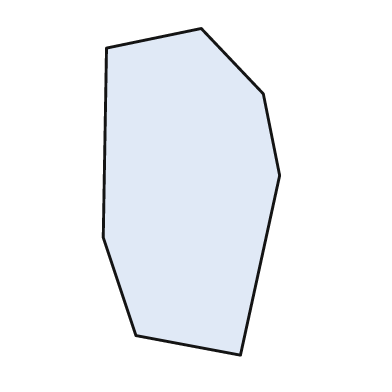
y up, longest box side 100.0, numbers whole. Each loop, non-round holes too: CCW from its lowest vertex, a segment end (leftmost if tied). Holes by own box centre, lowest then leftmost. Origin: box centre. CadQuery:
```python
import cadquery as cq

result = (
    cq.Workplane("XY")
    .moveTo(15.0, -50.0)
    .lineTo(27.0, 5.0)
    .lineTo(22.0, 30.0)
    .lineTo(3.0, 50.0)
    .lineTo(-26.0, 44.0)
    .lineTo(-27.0, -14.0)
    .lineTo(-17.0, -44.0)
    .close()
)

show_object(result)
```